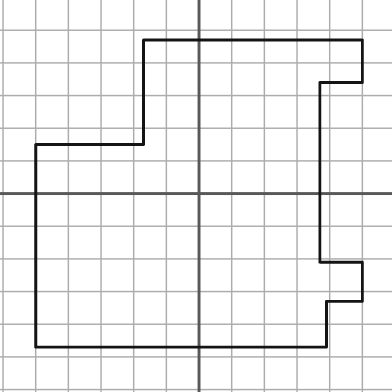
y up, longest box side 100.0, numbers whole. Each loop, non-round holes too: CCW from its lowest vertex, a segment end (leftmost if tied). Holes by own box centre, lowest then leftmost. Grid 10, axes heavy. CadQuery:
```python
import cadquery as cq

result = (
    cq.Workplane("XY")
    .moveTo(-50.0, -47.0)
    .lineTo(39.0, -47.0)
    .lineTo(39.0, -33.0)
    .lineTo(50.0, -33.0)
    .lineTo(50.0, -21.0)
    .lineTo(37.0, -21.0)
    .lineTo(37.0, 34.0)
    .lineTo(50.0, 34.0)
    .lineTo(50.0, 47.0)
    .lineTo(-17.0, 47.0)
    .lineTo(-17.0, 15.0)
    .lineTo(-50.0, 15.0)
    .close()
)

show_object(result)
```